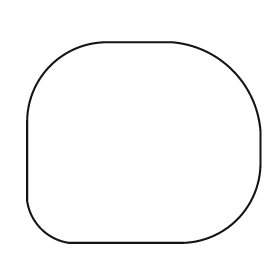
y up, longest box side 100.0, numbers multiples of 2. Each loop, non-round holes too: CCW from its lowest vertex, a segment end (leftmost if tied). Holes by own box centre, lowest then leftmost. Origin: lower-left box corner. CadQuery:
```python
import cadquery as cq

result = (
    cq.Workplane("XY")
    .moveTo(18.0, 0.0)
    .lineTo(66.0, 0.0)
    .threePointArc((90.0, 10.0), (100.0, 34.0))
    .lineTo(100.0, 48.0)
    .threePointArc((88.0, 74.0), (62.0, 86.0))
    .lineTo(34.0, 86.0)
    .threePointArc((10.0, 76.0), (0.0, 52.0))
    .lineTo(0.0, 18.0)
    .threePointArc((6.0, 6.0), (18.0, 0.0))
    .close()
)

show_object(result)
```